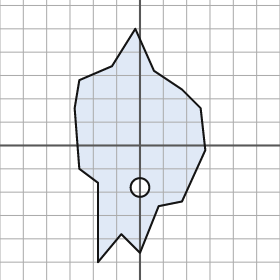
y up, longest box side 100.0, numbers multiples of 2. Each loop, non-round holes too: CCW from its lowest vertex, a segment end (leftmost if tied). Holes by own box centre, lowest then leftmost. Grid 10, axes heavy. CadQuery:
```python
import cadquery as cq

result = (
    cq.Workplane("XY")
    .moveTo(-18.0, -50.0)
    .lineTo(-8.0, -38.0)
    .lineTo(0.0, -46.0)
    .lineTo(8.0, -26.0)
    .lineTo(18.0, -24.0)
    .lineTo(28.0, -2.0)
    .lineTo(26.0, 16.0)
    .lineTo(18.0, 24.0)
    .lineTo(6.0, 32.0)
    .lineTo(-2.0, 50.0)
    .lineTo(-12.0, 34.0)
    .lineTo(-26.0, 28.0)
    .lineTo(-28.0, 16.0)
    .lineTo(-26.0, -10.0)
    .lineTo(-18.0, -16.0)
    .close()
    .moveTo(0.0, -18.0)
    .circle(4.0)
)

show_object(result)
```